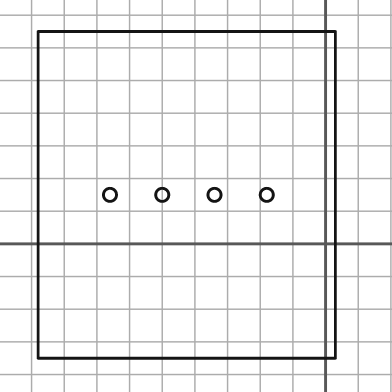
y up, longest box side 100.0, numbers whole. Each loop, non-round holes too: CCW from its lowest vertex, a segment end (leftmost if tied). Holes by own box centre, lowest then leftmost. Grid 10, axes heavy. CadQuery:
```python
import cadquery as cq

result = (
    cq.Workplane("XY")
    .moveTo(-88.0, -35.0)
    .lineTo(3.0, -35.0)
    .lineTo(3.0, 65.0)
    .lineTo(-88.0, 65.0)
    .close()
    .moveTo(-66.0, 15.0)
    .circle(2.0)
    .moveTo(-50.0, 15.0)
    .circle(2.0)
    .moveTo(-34.0, 15.0)
    .circle(2.0)
    .moveTo(-18.0, 15.0)
    .circle(2.0)
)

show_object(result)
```